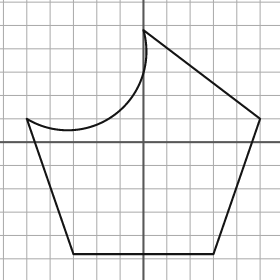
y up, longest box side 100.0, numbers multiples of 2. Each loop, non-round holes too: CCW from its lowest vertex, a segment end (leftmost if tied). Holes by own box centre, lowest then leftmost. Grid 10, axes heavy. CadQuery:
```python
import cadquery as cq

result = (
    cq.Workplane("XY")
    .moveTo(-30.0, -48.0)
    .lineTo(30.0, -48.0)
    .lineTo(50.0, 10.0)
    .lineTo(0.0, 48.0)
    .threePointArc((-12.0, 12.0), (-50.0, 10.0))
    .close()
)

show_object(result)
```